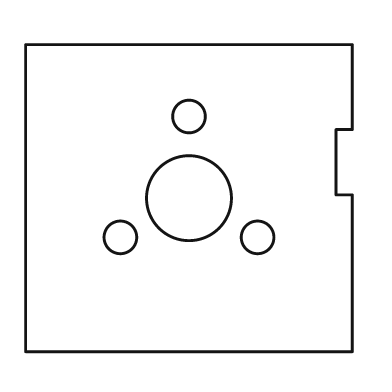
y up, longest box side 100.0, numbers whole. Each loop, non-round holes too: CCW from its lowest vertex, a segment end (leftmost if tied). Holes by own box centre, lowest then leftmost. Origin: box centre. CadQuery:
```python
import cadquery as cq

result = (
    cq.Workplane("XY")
    .moveTo(-50.0, -47.0)
    .lineTo(50.0, -47.0)
    .lineTo(50.0, 1.0)
    .lineTo(45.0, 1.0)
    .lineTo(45.0, 21.0)
    .lineTo(50.0, 21.0)
    .lineTo(50.0, 47.0)
    .lineTo(-50.0, 47.0)
    .close()
    .moveTo(-21.0, -12.0)
    .circle(5.0)
    .moveTo(21.0, -12.0)
    .circle(5.0)
    .moveTo(0.0, 0.0)
    .circle(13.0)
    .moveTo(0.0, 25.0)
    .circle(5.0)
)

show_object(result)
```